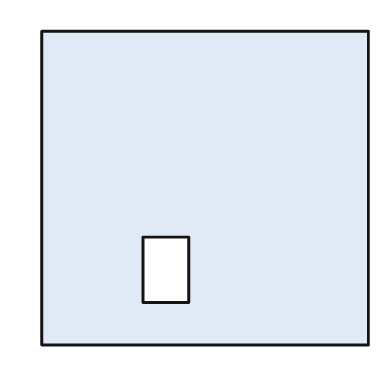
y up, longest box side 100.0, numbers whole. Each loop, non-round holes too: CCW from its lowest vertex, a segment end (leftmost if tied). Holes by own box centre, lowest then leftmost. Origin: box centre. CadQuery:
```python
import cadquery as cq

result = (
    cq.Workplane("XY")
    .moveTo(-50.0, -48.0)
    .lineTo(50.0, -48.0)
    .lineTo(50.0, 48.0)
    .lineTo(-50.0, 48.0)
    .close()
    .moveTo(-19.0, -35.0)
    .lineTo(-5.0, -35.0)
    .lineTo(-5.0, -15.0)
    .lineTo(-19.0, -15.0)
    .close()
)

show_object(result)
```